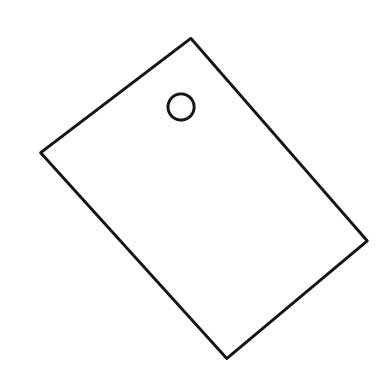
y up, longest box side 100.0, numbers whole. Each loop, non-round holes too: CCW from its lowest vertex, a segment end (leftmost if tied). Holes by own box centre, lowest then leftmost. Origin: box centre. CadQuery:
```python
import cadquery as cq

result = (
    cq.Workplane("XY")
    .moveTo(7.0, -49.0)
    .lineTo(50.0, -13.0)
    .lineTo(-4.0, 49.0)
    .lineTo(-50.0, 14.0)
    .close()
    .moveTo(-7.0, 28.0)
    .circle(4.0)
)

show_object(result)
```